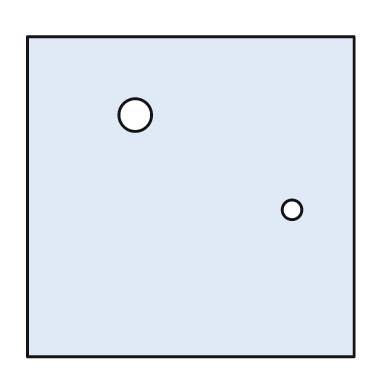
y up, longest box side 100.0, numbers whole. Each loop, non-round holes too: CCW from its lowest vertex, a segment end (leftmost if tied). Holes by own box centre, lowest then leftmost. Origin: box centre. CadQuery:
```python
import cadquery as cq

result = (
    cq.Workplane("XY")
    .moveTo(-50.0, -49.0)
    .lineTo(50.0, -49.0)
    .lineTo(50.0, 49.0)
    .lineTo(-50.0, 49.0)
    .close()
    .moveTo(31.0, -4.0)
    .circle(3.0)
    .moveTo(-17.0, 25.0)
    .circle(5.0)
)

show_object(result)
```